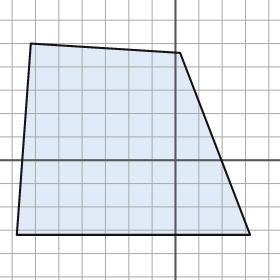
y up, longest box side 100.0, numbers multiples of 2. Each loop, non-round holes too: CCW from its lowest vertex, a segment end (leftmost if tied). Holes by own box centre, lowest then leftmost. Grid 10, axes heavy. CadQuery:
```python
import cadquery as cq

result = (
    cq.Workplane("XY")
    .moveTo(-68.0, -32.0)
    .lineTo(32.0, -32.0)
    .lineTo(2.0, 46.0)
    .lineTo(-62.0, 50.0)
    .close()
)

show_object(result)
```